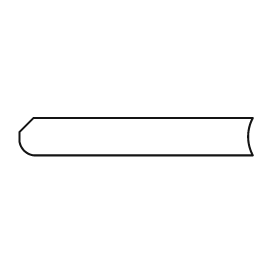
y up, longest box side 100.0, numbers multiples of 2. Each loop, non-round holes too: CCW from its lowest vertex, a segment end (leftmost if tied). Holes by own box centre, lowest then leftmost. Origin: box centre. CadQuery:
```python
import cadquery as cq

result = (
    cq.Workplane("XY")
    .moveTo(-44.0, -8.0)
    .lineTo(50.0, -8.0)
    .threePointArc((48.0, 0.0), (50.0, 8.0))
    .lineTo(-44.0, 8.0)
    .lineTo(-50.0, 2.0)
    .lineTo(-50.0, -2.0)
    .threePointArc((-48.0, -6.0), (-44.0, -8.0))
    .close()
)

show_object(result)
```